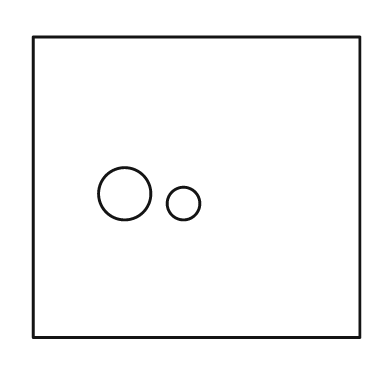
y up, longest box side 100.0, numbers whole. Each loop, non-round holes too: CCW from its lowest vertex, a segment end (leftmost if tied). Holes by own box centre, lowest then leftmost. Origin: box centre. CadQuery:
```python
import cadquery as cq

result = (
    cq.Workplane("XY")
    .moveTo(-50.0, -46.0)
    .lineTo(50.0, -46.0)
    .lineTo(50.0, 46.0)
    .lineTo(-50.0, 46.0)
    .close()
    .moveTo(-4.0, -5.0)
    .circle(5.0)
    .moveTo(-22.0, -2.0)
    .circle(8.0)
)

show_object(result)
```